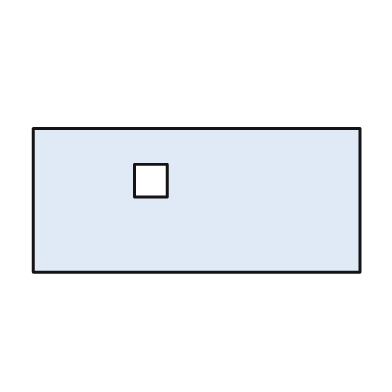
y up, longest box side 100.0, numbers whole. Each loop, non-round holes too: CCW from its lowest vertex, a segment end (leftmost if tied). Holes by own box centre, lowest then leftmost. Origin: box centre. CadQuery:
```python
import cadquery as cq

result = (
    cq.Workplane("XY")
    .moveTo(-50.0, -22.0)
    .lineTo(50.0, -22.0)
    .lineTo(50.0, 22.0)
    .lineTo(-50.0, 22.0)
    .close()
    .moveTo(-19.0, 1.0)
    .lineTo(-9.0, 1.0)
    .lineTo(-9.0, 11.0)
    .lineTo(-19.0, 11.0)
    .close()
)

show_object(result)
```